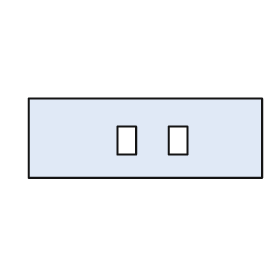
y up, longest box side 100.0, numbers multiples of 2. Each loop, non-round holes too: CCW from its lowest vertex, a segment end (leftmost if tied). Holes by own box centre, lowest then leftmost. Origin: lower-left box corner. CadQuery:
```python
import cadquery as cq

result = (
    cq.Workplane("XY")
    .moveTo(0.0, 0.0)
    .lineTo(100.0, 0.0)
    .lineTo(100.0, 34.0)
    .lineTo(0.0, 34.0)
    .close()
    .moveTo(38.0, 10.0)
    .lineTo(46.0, 10.0)
    .lineTo(46.0, 22.0)
    .lineTo(38.0, 22.0)
    .close()
    .moveTo(60.0, 10.0)
    .lineTo(68.0, 10.0)
    .lineTo(68.0, 22.0)
    .lineTo(60.0, 22.0)
    .close()
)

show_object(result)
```